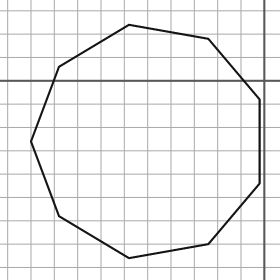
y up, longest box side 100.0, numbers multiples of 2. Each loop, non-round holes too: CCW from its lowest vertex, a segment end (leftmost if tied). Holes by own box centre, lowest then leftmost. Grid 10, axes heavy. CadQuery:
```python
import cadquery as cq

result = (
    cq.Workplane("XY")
    .moveTo(-58.0, -76.0)
    .lineTo(-24.0, -70.0)
    .lineTo(-2.0, -44.0)
    .lineTo(-2.0, -8.0)
    .lineTo(-24.0, 18.0)
    .lineTo(-58.0, 24.0)
    .lineTo(-88.0, 6.0)
    .lineTo(-100.0, -26.0)
    .lineTo(-88.0, -58.0)
    .close()
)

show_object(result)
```